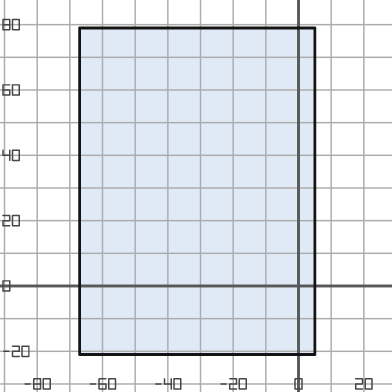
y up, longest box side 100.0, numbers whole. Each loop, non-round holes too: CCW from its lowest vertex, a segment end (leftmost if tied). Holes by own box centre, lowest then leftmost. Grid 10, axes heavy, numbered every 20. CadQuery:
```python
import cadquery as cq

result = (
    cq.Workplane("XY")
    .moveTo(-67.0, -21.0)
    .lineTo(5.0, -21.0)
    .lineTo(5.0, 79.0)
    .lineTo(-67.0, 79.0)
    .close()
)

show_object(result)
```